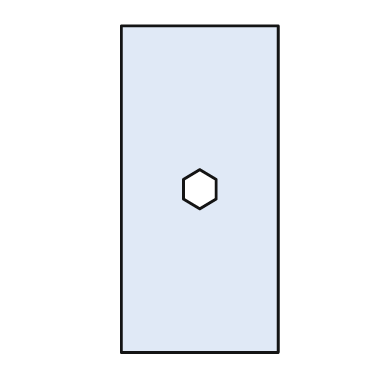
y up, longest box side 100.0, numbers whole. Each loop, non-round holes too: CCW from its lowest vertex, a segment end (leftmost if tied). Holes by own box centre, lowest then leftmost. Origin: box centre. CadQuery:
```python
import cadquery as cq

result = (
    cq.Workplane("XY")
    .moveTo(-24.0, -50.0)
    .lineTo(24.0, -50.0)
    .lineTo(24.0, 50.0)
    .lineTo(-24.0, 50.0)
    .close()
    .moveTo(0.0, -6.0)
    .lineTo(5.0, -3.0)
    .lineTo(5.0, 3.0)
    .lineTo(0.0, 6.0)
    .lineTo(-5.0, 3.0)
    .lineTo(-5.0, -3.0)
    .close()
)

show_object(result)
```